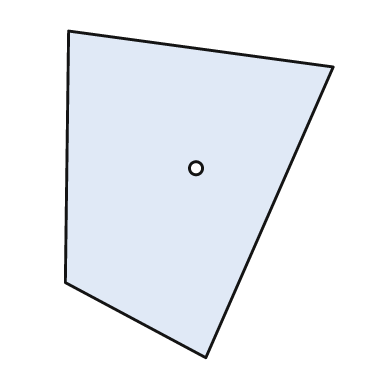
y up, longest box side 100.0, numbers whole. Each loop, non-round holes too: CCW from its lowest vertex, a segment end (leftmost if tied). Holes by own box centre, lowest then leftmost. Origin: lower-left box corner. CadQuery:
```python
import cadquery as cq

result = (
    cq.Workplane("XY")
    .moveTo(43.0, 0.0)
    .lineTo(82.0, 89.0)
    .lineTo(1.0, 100.0)
    .lineTo(0.0, 23.0)
    .close()
    .moveTo(40.0, 58.0)
    .circle(2.0)
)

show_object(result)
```